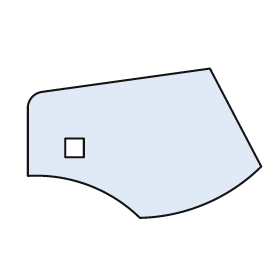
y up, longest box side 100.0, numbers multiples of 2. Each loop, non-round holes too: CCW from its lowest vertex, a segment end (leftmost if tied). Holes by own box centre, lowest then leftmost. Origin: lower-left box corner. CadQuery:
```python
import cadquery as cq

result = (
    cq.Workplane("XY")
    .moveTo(48.0, 0.0)
    .threePointArc((76.0, 6.0), (100.0, 22.0))
    .lineTo(78.0, 64.0)
    .lineTo(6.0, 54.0)
    .threePointArc((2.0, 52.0), (0.0, 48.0))
    .lineTo(0.0, 18.0)
    .threePointArc((26.0, 14.0), (48.0, 0.0))
    .close()
    .moveTo(16.0, 26.0)
    .lineTo(24.0, 26.0)
    .lineTo(24.0, 34.0)
    .lineTo(16.0, 34.0)
    .close()
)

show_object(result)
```